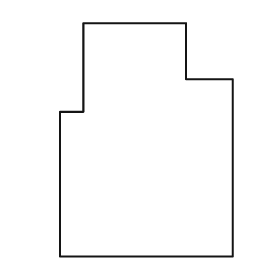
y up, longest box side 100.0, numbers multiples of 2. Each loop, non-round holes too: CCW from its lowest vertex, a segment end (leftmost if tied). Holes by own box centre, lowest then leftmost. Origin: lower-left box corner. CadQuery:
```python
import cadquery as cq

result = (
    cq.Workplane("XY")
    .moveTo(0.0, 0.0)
    .lineTo(74.0, 0.0)
    .lineTo(74.0, 76.0)
    .lineTo(54.0, 76.0)
    .lineTo(54.0, 100.0)
    .lineTo(10.0, 100.0)
    .lineTo(10.0, 62.0)
    .lineTo(0.0, 62.0)
    .close()
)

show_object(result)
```